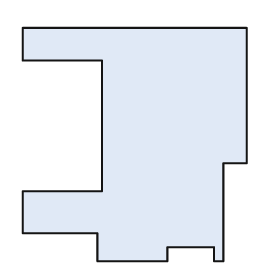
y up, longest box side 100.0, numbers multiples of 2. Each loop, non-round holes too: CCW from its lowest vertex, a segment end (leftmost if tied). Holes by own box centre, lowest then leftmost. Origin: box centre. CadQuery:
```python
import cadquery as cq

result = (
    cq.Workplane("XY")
    .moveTo(-16.0, -50.0)
    .lineTo(14.0, -50.0)
    .lineTo(14.0, -44.0)
    .lineTo(34.0, -44.0)
    .lineTo(34.0, -50.0)
    .lineTo(38.0, -50.0)
    .lineTo(38.0, -8.0)
    .lineTo(48.0, -8.0)
    .lineTo(48.0, 50.0)
    .lineTo(-48.0, 50.0)
    .lineTo(-48.0, 36.0)
    .lineTo(-14.0, 36.0)
    .lineTo(-14.0, -20.0)
    .lineTo(-48.0, -20.0)
    .lineTo(-48.0, -38.0)
    .lineTo(-16.0, -38.0)
    .close()
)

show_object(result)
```